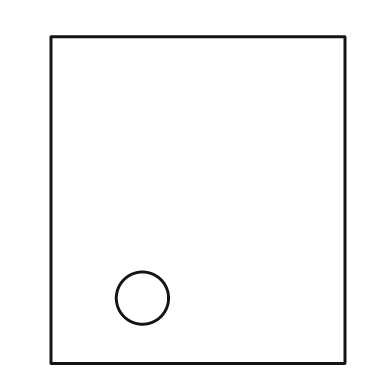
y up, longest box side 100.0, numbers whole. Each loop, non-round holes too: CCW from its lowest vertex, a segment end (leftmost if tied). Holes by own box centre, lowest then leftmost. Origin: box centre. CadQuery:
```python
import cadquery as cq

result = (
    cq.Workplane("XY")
    .moveTo(-45.0, -50.0)
    .lineTo(45.0, -50.0)
    .lineTo(45.0, 50.0)
    .lineTo(-45.0, 50.0)
    .close()
    .moveTo(-17.0, -30.0)
    .circle(8.0)
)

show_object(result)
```